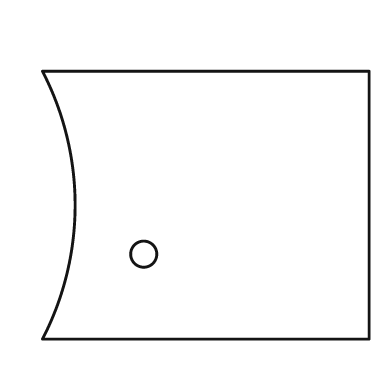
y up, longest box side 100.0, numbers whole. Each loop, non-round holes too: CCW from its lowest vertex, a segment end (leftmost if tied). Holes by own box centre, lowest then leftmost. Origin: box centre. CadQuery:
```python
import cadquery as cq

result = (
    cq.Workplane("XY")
    .moveTo(-50.0, -41.0)
    .lineTo(50.0, -41.0)
    .lineTo(50.0, 41.0)
    .lineTo(-50.0, 41.0)
    .threePointArc((-40.0, 0.0), (-50.0, -41.0))
    .close()
    .moveTo(-19.0, -15.0)
    .circle(4.0)
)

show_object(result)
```